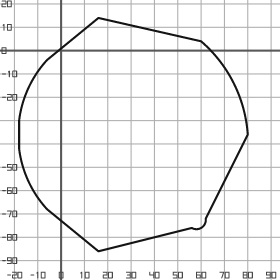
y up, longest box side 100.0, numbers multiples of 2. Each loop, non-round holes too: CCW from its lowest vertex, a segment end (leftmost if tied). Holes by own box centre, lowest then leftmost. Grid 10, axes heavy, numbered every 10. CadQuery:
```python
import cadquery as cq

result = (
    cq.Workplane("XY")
    .moveTo(16.0, -86.0)
    .lineTo(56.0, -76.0)
    .threePointArc((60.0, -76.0), (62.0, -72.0))
    .lineTo(80.0, -36.0)
    .threePointArc((74.0, -14.0), (60.0, 4.0))
    .lineTo(16.0, 14.0)
    .lineTo(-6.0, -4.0)
    .threePointArc((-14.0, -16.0), (-18.0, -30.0))
    .lineTo(-18.0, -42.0)
    .threePointArc((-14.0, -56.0), (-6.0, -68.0))
    .close()
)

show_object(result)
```